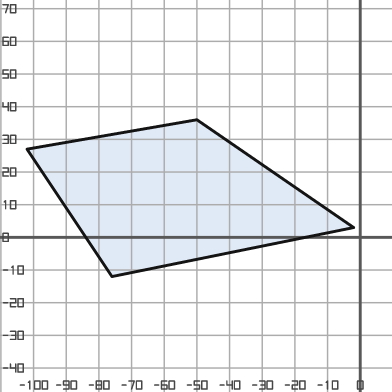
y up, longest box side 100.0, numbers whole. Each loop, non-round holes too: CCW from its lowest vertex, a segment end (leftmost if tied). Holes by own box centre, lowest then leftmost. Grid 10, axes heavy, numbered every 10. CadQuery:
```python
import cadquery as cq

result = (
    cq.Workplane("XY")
    .moveTo(-76.0, -12.0)
    .lineTo(-2.0, 3.0)
    .lineTo(-50.0, 36.0)
    .lineTo(-102.0, 27.0)
    .close()
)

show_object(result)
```